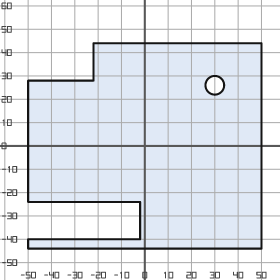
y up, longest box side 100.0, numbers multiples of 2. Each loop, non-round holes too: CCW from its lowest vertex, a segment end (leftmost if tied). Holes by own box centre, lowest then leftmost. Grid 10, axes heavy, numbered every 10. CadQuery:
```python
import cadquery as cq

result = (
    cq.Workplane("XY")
    .moveTo(-50.0, -44.0)
    .lineTo(50.0, -44.0)
    .lineTo(50.0, 44.0)
    .lineTo(-22.0, 44.0)
    .lineTo(-22.0, 28.0)
    .lineTo(-50.0, 28.0)
    .lineTo(-50.0, -24.0)
    .lineTo(-2.0, -24.0)
    .lineTo(-2.0, -40.0)
    .lineTo(-50.0, -40.0)
    .close()
    .moveTo(30.0, 26.0)
    .circle(4.0)
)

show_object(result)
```